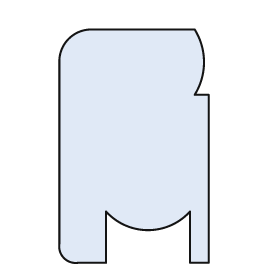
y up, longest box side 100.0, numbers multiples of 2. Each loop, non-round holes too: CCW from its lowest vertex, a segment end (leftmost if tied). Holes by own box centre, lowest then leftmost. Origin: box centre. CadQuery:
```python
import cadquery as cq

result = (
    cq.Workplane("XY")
    .moveTo(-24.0, -50.0)
    .lineTo(-12.0, -50.0)
    .lineTo(-12.0, -28.0)
    .threePointArc((6.0, -36.0), (24.0, -28.0))
    .lineTo(24.0, -50.0)
    .lineTo(32.0, -50.0)
    .lineTo(32.0, 22.0)
    .lineTo(26.0, 22.0)
    .threePointArc((30.0, 36.0), (26.0, 50.0))
    .lineTo(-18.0, 50.0)
    .threePointArc((-28.0, 46.0), (-32.0, 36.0))
    .lineTo(-32.0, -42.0)
    .threePointArc((-30.0, -48.0), (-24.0, -50.0))
    .close()
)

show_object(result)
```